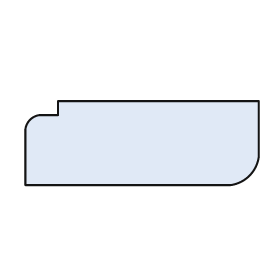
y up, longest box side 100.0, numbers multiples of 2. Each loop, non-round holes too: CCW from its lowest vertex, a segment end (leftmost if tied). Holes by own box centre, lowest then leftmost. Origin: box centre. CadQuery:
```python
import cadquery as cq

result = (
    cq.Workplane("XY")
    .moveTo(-50.0, -18.0)
    .lineTo(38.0, -18.0)
    .threePointArc((46.0, -14.0), (50.0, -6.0))
    .lineTo(50.0, 18.0)
    .lineTo(-36.0, 18.0)
    .lineTo(-36.0, 12.0)
    .lineTo(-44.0, 12.0)
    .threePointArc((-48.0, 10.0), (-50.0, 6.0))
    .close()
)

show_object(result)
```